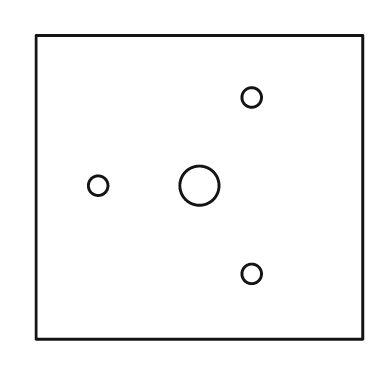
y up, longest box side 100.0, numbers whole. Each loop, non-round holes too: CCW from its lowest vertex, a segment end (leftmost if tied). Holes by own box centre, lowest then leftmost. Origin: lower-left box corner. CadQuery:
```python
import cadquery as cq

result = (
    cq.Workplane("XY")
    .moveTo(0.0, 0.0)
    .lineTo(100.0, 0.0)
    .lineTo(100.0, 93.0)
    .lineTo(0.0, 93.0)
    .close()
    .moveTo(66.0, 20.0)
    .circle(3.0)
    .moveTo(19.0, 47.0)
    .circle(3.0)
    .moveTo(50.0, 47.0)
    .circle(6.0)
    .moveTo(66.0, 74.0)
    .circle(3.0)
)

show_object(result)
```